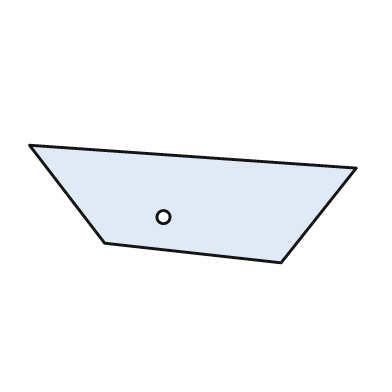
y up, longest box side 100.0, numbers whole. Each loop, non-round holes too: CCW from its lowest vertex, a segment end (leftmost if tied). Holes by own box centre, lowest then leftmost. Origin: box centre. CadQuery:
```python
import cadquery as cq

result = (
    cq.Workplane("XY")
    .moveTo(27.0, -18.0)
    .lineTo(50.0, 11.0)
    .lineTo(-50.0, 18.0)
    .lineTo(-27.0, -12.0)
    .close()
    .moveTo(-9.0, -4.0)
    .circle(2.0)
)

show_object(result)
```